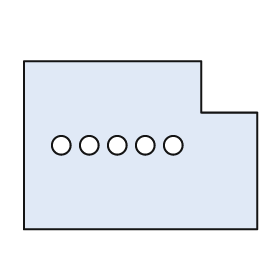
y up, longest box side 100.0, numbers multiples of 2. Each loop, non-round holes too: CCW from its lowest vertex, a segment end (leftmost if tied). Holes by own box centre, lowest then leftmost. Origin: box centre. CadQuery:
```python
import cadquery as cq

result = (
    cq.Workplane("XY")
    .moveTo(-50.0, -36.0)
    .lineTo(50.0, -36.0)
    .lineTo(50.0, 14.0)
    .lineTo(26.0, 14.0)
    .lineTo(26.0, 36.0)
    .lineTo(-50.0, 36.0)
    .close()
    .moveTo(-34.0, 0.0)
    .circle(4.0)
    .moveTo(-22.0, 0.0)
    .circle(4.0)
    .moveTo(-10.0, 0.0)
    .circle(4.0)
    .moveTo(2.0, 0.0)
    .circle(4.0)
    .moveTo(14.0, 0.0)
    .circle(4.0)
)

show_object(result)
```